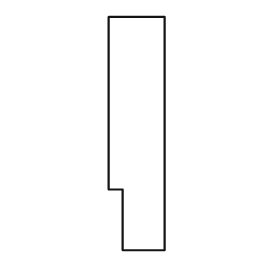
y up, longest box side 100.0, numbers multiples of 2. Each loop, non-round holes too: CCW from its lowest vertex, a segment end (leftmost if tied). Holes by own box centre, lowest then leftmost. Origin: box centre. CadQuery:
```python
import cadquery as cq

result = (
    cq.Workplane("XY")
    .moveTo(-6.0, -50.0)
    .lineTo(12.0, -50.0)
    .lineTo(12.0, 50.0)
    .lineTo(-12.0, 50.0)
    .lineTo(-12.0, -24.0)
    .lineTo(-6.0, -24.0)
    .close()
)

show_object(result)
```